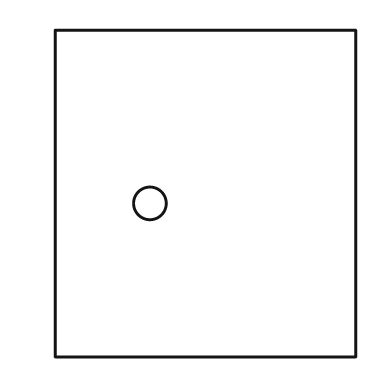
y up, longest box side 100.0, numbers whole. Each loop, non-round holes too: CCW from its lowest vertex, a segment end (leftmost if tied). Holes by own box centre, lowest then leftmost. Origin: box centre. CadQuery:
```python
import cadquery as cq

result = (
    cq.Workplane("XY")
    .moveTo(-46.0, -50.0)
    .lineTo(46.0, -50.0)
    .lineTo(46.0, 50.0)
    .lineTo(-46.0, 50.0)
    .close()
    .moveTo(-17.0, -3.0)
    .circle(5.0)
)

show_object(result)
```